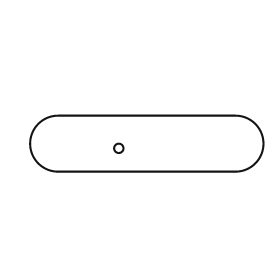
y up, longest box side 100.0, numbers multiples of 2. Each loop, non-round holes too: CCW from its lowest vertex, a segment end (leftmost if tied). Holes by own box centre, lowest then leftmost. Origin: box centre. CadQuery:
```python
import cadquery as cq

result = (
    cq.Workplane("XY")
    .moveTo(-38.0, -12.0)
    .lineTo(38.0, -12.0)
    .threePointArc((50.0, 0.0), (38.0, 12.0))
    .lineTo(-38.0, 12.0)
    .threePointArc((-50.0, 0.0), (-38.0, -12.0))
    .close()
    .moveTo(-12.0, -2.0)
    .circle(2.0)
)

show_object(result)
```